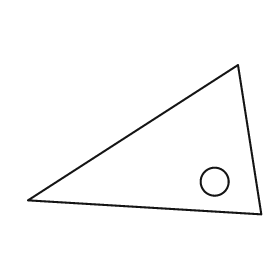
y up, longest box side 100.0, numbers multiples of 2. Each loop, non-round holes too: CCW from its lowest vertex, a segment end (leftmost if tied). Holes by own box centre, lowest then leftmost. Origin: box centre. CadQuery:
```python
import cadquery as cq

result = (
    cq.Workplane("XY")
    .moveTo(50.0, -32.0)
    .lineTo(40.0, 32.0)
    .lineTo(-50.0, -26.0)
    .close()
    .moveTo(30.0, -18.0)
    .circle(6.0)
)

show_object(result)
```